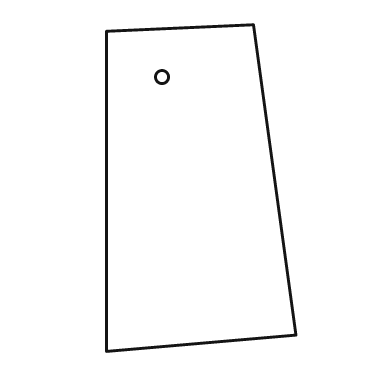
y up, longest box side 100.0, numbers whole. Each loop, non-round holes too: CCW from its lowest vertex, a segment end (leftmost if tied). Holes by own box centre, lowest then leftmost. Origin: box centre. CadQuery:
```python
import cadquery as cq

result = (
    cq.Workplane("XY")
    .moveTo(-29.0, -50.0)
    .lineTo(29.0, -45.0)
    .lineTo(16.0, 50.0)
    .lineTo(-29.0, 48.0)
    .close()
    .moveTo(-12.0, 34.0)
    .circle(2.0)
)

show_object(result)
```